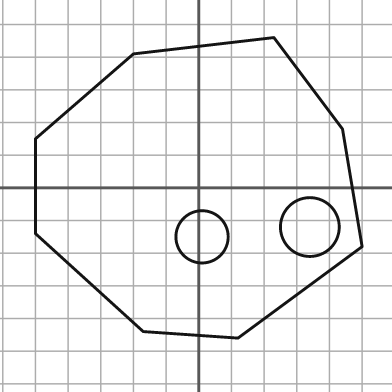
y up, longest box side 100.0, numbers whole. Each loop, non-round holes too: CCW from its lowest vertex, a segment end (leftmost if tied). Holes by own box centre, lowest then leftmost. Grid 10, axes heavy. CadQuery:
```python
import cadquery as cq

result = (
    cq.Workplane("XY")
    .moveTo(12.0, -46.0)
    .lineTo(50.0, -18.0)
    .lineTo(44.0, 18.0)
    .lineTo(23.0, 46.0)
    .lineTo(-20.0, 41.0)
    .lineTo(-50.0, 15.0)
    .lineTo(-50.0, -14.0)
    .lineTo(-17.0, -44.0)
    .close()
    .moveTo(1.0, -15.0)
    .circle(8.0)
    .moveTo(34.0, -12.0)
    .circle(9.0)
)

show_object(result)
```